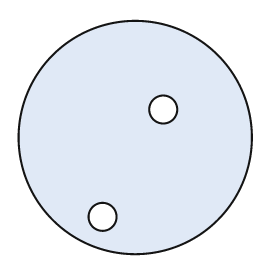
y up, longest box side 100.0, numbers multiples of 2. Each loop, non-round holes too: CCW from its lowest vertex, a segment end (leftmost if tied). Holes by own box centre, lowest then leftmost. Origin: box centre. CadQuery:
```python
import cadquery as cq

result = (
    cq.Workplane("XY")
    .moveTo(0.0, 0.0)
    .circle(50.0)
    .moveTo(-14.0, -34.0)
    .circle(6.0)
    .moveTo(12.0, 12.0)
    .circle(6.0)
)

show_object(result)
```